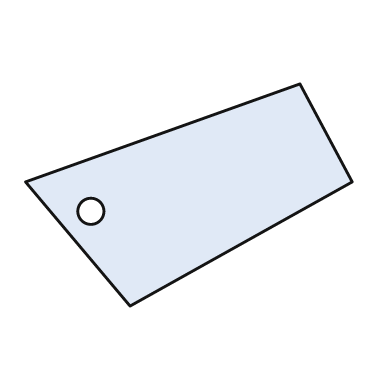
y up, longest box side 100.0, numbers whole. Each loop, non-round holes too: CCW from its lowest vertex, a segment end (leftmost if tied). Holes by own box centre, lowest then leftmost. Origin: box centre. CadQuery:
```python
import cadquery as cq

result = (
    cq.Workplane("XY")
    .moveTo(-18.0, -34.0)
    .lineTo(50.0, 4.0)
    .lineTo(34.0, 34.0)
    .lineTo(-50.0, 4.0)
    .close()
    .moveTo(-30.0, -5.0)
    .circle(4.0)
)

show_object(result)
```